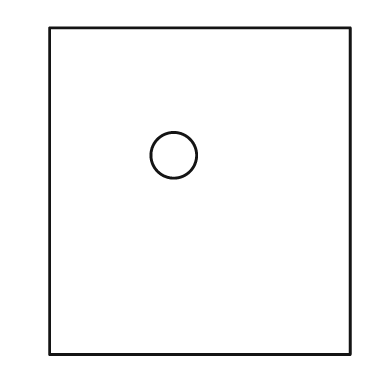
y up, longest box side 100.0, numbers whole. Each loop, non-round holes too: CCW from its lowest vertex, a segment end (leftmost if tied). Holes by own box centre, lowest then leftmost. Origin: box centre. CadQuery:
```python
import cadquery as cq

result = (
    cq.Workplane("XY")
    .moveTo(-46.0, -50.0)
    .lineTo(46.0, -50.0)
    .lineTo(46.0, 50.0)
    .lineTo(-46.0, 50.0)
    .close()
    .moveTo(-8.0, 11.0)
    .circle(7.0)
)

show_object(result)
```